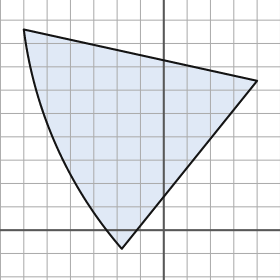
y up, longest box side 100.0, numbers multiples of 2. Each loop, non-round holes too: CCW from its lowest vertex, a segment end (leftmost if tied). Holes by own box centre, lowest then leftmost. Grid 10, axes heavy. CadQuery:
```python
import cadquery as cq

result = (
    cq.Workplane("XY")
    .moveTo(-18.0, -8.0)
    .lineTo(40.0, 64.0)
    .lineTo(-60.0, 86.0)
    .threePointArc((-46.0, 36.0), (-18.0, -8.0))
    .close()
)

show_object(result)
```